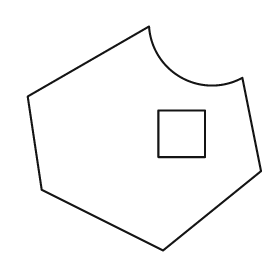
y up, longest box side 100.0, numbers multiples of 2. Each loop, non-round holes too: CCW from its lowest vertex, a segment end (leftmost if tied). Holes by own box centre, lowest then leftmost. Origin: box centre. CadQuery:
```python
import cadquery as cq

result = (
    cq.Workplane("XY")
    .moveTo(8.0, -48.0)
    .lineTo(50.0, -14.0)
    .lineTo(42.0, 26.0)
    .threePointArc((16.0, 26.0), (2.0, 48.0))
    .lineTo(-50.0, 18.0)
    .lineTo(-44.0, -22.0)
    .close()
    .moveTo(6.0, -8.0)
    .lineTo(26.0, -8.0)
    .lineTo(26.0, 12.0)
    .lineTo(6.0, 12.0)
    .close()
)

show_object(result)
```